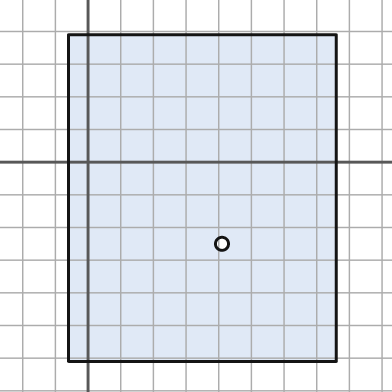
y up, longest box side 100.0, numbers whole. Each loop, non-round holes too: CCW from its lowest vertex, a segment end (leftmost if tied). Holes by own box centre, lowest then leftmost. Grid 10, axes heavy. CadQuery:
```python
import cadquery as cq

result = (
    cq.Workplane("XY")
    .moveTo(-6.0, -61.0)
    .lineTo(76.0, -61.0)
    .lineTo(76.0, 39.0)
    .lineTo(-6.0, 39.0)
    .close()
    .moveTo(41.0, -25.0)
    .circle(2.0)
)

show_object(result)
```